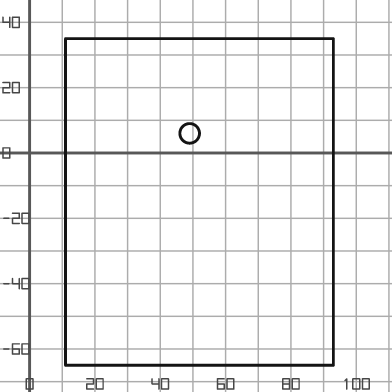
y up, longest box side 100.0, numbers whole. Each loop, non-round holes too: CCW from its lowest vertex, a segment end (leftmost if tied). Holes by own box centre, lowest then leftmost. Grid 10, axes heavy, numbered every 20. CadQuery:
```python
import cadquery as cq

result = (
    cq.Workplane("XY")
    .moveTo(11.0, -65.0)
    .lineTo(93.0, -65.0)
    .lineTo(93.0, 35.0)
    .lineTo(11.0, 35.0)
    .close()
    .moveTo(49.0, 6.0)
    .circle(3.0)
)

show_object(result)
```